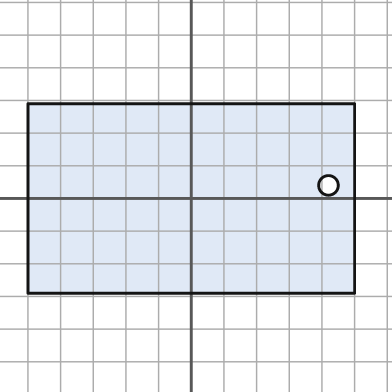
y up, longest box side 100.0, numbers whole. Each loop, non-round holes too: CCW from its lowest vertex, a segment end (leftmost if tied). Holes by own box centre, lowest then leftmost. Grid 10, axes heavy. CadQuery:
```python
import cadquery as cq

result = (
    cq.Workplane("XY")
    .moveTo(-50.0, -29.0)
    .lineTo(50.0, -29.0)
    .lineTo(50.0, 29.0)
    .lineTo(-50.0, 29.0)
    .close()
    .moveTo(42.0, 4.0)
    .circle(3.0)
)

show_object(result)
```